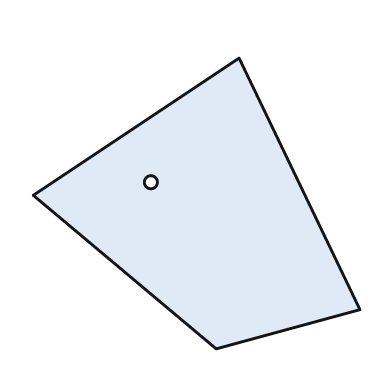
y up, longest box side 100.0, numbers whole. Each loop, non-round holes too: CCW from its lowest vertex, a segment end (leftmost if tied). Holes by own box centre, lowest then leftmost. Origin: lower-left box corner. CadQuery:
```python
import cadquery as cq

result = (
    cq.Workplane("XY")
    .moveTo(56.0, 0.0)
    .lineTo(100.0, 12.0)
    .lineTo(63.0, 89.0)
    .lineTo(0.0, 47.0)
    .close()
    .moveTo(36.0, 51.0)
    .circle(2.0)
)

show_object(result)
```